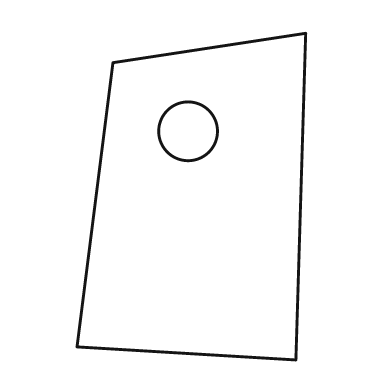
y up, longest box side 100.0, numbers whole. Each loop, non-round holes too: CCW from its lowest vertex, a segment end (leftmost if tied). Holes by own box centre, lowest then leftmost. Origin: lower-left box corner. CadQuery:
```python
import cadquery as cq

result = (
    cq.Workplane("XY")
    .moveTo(67.0, 0.0)
    .lineTo(70.0, 100.0)
    .lineTo(11.0, 91.0)
    .lineTo(0.0, 4.0)
    .close()
    .moveTo(34.0, 70.0)
    .circle(9.0)
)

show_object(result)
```